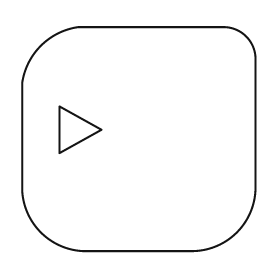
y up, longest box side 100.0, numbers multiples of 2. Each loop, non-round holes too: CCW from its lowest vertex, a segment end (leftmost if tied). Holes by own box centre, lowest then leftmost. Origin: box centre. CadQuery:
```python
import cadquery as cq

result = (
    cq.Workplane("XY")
    .moveTo(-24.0, -48.0)
    .lineTo(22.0, -48.0)
    .threePointArc((42.0, -40.0), (50.0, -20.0))
    .lineTo(50.0, 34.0)
    .threePointArc((46.0, 44.0), (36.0, 48.0))
    .lineTo(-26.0, 48.0)
    .threePointArc((-42.0, 40.0), (-50.0, 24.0))
    .lineTo(-50.0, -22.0)
    .threePointArc((-42.0, -40.0), (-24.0, -48.0))
    .close()
    .moveTo(-34.0, -6.0)
    .lineTo(-16.0, 4.0)
    .lineTo(-34.0, 14.0)
    .close()
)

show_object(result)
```